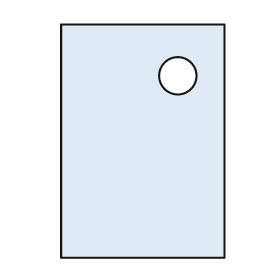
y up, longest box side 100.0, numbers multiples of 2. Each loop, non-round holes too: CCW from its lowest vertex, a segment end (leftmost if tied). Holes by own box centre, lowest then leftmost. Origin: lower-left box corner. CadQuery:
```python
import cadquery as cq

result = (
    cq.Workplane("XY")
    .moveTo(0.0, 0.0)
    .lineTo(70.0, 0.0)
    .lineTo(70.0, 100.0)
    .lineTo(0.0, 100.0)
    .close()
    .moveTo(50.0, 78.0)
    .circle(8.0)
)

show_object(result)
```